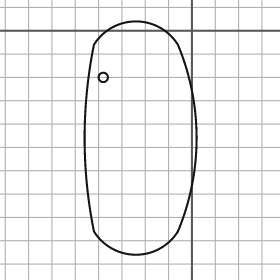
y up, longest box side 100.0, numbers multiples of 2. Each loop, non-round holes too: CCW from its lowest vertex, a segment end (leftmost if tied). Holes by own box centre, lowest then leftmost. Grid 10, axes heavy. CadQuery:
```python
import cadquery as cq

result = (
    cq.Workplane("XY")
    .moveTo(-42.0, -86.0)
    .threePointArc((-24.0, -96.0), (-6.0, -86.0))
    .threePointArc((2.0, -46.0), (-6.0, -6.0))
    .threePointArc((-24.0, 4.0), (-42.0, -6.0))
    .threePointArc((-46.0, -46.0), (-42.0, -86.0))
    .close()
    .moveTo(-38.0, -20.0)
    .circle(2.0)
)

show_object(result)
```